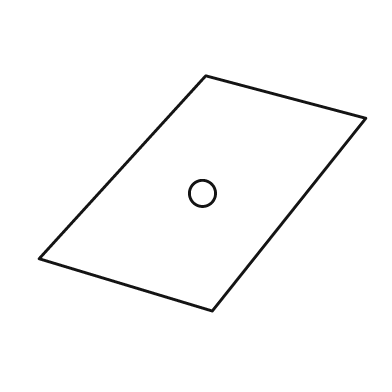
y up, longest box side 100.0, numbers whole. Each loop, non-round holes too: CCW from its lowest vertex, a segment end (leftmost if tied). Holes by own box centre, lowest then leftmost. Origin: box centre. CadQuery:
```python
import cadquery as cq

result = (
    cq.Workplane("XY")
    .moveTo(3.0, -36.0)
    .lineTo(50.0, 23.0)
    .lineTo(1.0, 36.0)
    .lineTo(-50.0, -20.0)
    .close()
    .moveTo(0.0, 0.0)
    .circle(4.0)
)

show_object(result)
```